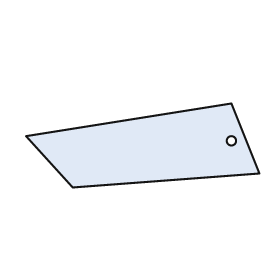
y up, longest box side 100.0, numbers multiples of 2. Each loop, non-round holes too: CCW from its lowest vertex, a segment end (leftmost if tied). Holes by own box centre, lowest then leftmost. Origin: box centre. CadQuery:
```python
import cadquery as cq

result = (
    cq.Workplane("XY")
    .moveTo(-30.0, -18.0)
    .lineTo(50.0, -12.0)
    .lineTo(38.0, 18.0)
    .lineTo(-50.0, 4.0)
    .close()
    .moveTo(38.0, 2.0)
    .circle(2.0)
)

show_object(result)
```